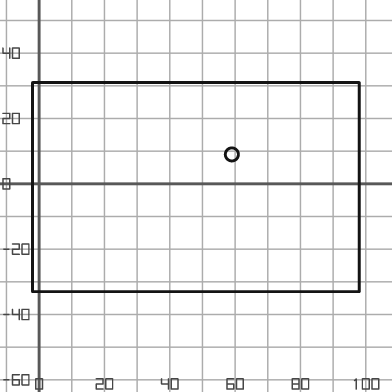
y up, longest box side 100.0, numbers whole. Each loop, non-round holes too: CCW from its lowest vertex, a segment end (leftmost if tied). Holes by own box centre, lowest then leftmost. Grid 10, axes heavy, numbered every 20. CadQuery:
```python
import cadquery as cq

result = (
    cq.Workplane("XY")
    .moveTo(-2.0, -33.0)
    .lineTo(98.0, -33.0)
    .lineTo(98.0, 31.0)
    .lineTo(-2.0, 31.0)
    .close()
    .moveTo(59.0, 9.0)
    .circle(2.0)
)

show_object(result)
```